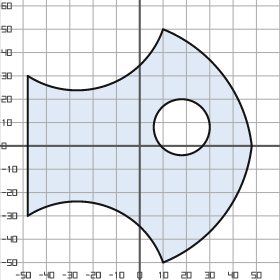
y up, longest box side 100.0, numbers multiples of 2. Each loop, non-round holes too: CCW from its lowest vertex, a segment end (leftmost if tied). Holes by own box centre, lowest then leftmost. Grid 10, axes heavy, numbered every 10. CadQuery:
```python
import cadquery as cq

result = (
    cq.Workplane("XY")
    .moveTo(10.0, -50.0)
    .threePointArc((36.0, -30.0), (48.0, 0.0))
    .threePointArc((36.0, 30.0), (10.0, 50.0))
    .threePointArc((-14.0, 26.0), (-48.0, 30.0))
    .lineTo(-48.0, -30.0)
    .threePointArc((-14.0, -26.0), (10.0, -50.0))
    .close()
    .moveTo(18.0, 8.0)
    .circle(12.0)
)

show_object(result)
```